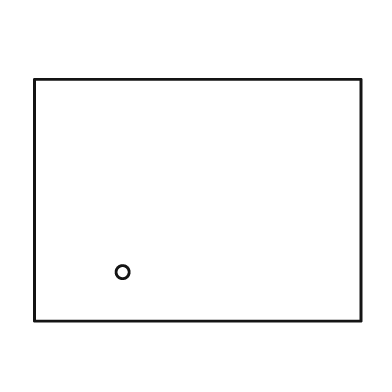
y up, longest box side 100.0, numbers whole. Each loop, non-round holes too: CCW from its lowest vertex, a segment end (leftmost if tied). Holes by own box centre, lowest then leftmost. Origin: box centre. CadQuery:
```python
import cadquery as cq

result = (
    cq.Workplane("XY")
    .moveTo(-50.0, -37.0)
    .lineTo(50.0, -37.0)
    .lineTo(50.0, 37.0)
    .lineTo(-50.0, 37.0)
    .close()
    .moveTo(-23.0, -22.0)
    .circle(2.0)
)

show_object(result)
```